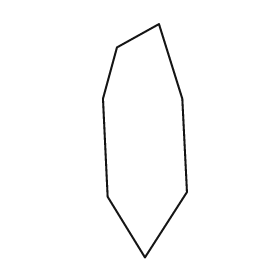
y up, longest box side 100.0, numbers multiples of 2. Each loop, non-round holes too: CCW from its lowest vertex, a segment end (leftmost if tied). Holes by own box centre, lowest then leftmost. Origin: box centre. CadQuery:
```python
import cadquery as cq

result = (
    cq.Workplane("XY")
    .moveTo(0.0, -50.0)
    .lineTo(18.0, -22.0)
    .lineTo(16.0, 18.0)
    .lineTo(6.0, 50.0)
    .lineTo(-12.0, 40.0)
    .lineTo(-18.0, 18.0)
    .lineTo(-16.0, -24.0)
    .close()
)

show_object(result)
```